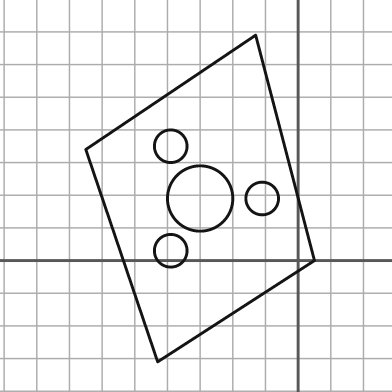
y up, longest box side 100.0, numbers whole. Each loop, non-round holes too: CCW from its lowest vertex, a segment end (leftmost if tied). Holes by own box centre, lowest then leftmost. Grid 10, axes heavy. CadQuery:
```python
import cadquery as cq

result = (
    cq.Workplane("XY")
    .moveTo(-43.0, -31.0)
    .lineTo(5.0, 0.0)
    .lineTo(-13.0, 69.0)
    .lineTo(-65.0, 34.0)
    .close()
    .moveTo(-39.0, 3.0)
    .circle(5.0)
    .moveTo(-30.0, 19.0)
    .circle(10.0)
    .moveTo(-11.0, 19.0)
    .circle(5.0)
    .moveTo(-39.0, 35.0)
    .circle(5.0)
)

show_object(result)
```